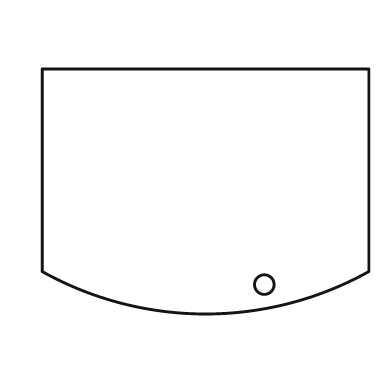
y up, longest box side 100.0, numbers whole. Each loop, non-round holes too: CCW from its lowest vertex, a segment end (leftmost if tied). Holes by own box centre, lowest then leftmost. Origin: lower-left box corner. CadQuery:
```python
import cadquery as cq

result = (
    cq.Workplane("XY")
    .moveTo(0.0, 13.0)
    .threePointArc((50.0, 0.0), (100.0, 13.0))
    .lineTo(100.0, 75.0)
    .lineTo(0.0, 75.0)
    .close()
    .moveTo(68.0, 9.0)
    .circle(3.0)
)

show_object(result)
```